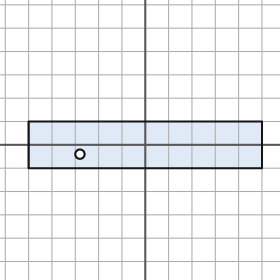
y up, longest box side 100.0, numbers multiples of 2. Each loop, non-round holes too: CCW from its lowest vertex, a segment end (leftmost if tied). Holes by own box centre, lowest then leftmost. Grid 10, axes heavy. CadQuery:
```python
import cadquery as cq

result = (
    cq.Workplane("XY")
    .moveTo(-50.0, -10.0)
    .lineTo(50.0, -10.0)
    .lineTo(50.0, 10.0)
    .lineTo(-50.0, 10.0)
    .close()
    .moveTo(-28.0, -4.0)
    .circle(2.0)
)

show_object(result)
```